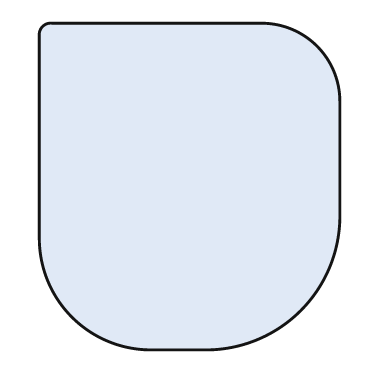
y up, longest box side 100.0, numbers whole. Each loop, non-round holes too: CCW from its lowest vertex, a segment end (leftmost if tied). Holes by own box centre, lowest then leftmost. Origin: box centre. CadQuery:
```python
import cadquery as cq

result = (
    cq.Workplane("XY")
    .moveTo(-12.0, -50.0)
    .lineTo(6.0, -50.0)
    .threePointArc((34.0, -38.0), (46.0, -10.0))
    .lineTo(46.0, 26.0)
    .threePointArc((39.0, 43.0), (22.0, 50.0))
    .lineTo(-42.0, 50.0)
    .threePointArc((-45.0, 49.0), (-46.0, 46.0))
    .lineTo(-46.0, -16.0)
    .threePointArc((-36.0, -40.0), (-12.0, -50.0))
    .close()
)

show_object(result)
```